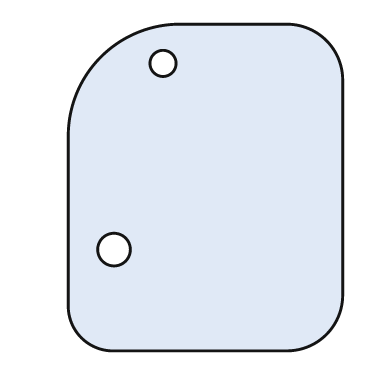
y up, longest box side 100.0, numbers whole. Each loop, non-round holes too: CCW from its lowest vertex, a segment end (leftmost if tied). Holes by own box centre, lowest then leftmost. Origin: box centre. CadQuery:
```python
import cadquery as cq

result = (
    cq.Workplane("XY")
    .moveTo(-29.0, -50.0)
    .lineTo(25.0, -50.0)
    .threePointArc((37.0, -45.0), (42.0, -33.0))
    .lineTo(42.0, 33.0)
    .threePointArc((37.0, 45.0), (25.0, 50.0))
    .lineTo(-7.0, 50.0)
    .threePointArc((-32.0, 40.0), (-42.0, 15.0))
    .lineTo(-42.0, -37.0)
    .threePointArc((-38.0, -46.0), (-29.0, -50.0))
    .close()
    .moveTo(-28.0, -19.0)
    .circle(5.0)
    .moveTo(-13.0, 38.0)
    .circle(4.0)
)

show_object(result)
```